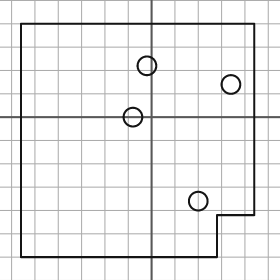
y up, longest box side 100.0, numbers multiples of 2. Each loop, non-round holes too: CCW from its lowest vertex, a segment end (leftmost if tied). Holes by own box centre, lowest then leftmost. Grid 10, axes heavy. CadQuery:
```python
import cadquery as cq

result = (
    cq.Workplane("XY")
    .moveTo(-56.0, -60.0)
    .lineTo(28.0, -60.0)
    .lineTo(28.0, -42.0)
    .lineTo(44.0, -42.0)
    .lineTo(44.0, 40.0)
    .lineTo(-56.0, 40.0)
    .close()
    .moveTo(20.0, -36.0)
    .circle(4.0)
    .moveTo(-8.0, 0.0)
    .circle(4.0)
    .moveTo(34.0, 14.0)
    .circle(4.0)
    .moveTo(-2.0, 22.0)
    .circle(4.0)
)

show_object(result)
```